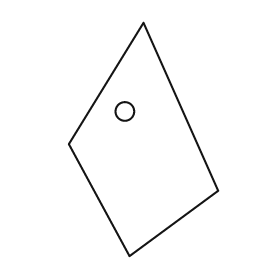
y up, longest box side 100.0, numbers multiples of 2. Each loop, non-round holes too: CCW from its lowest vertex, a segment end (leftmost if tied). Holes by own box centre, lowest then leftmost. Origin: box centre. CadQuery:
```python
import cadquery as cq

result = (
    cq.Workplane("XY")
    .moveTo(-6.0, -50.0)
    .lineTo(32.0, -22.0)
    .lineTo(0.0, 50.0)
    .lineTo(-32.0, -2.0)
    .close()
    .moveTo(-8.0, 12.0)
    .circle(4.0)
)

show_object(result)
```